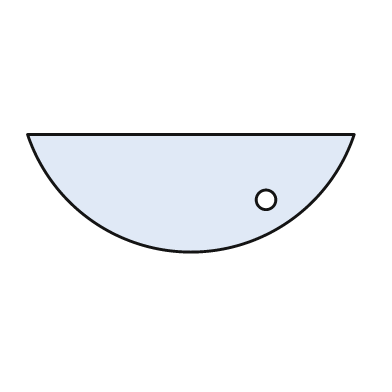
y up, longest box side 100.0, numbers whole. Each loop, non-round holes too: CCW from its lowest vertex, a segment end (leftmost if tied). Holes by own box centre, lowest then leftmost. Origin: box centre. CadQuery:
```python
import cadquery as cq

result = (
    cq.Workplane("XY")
    .moveTo(-50.0, 18.0)
    .threePointArc((0.0, -18.0), (50.0, 18.0))
    .close()
    .moveTo(23.0, -2.0)
    .circle(3.0)
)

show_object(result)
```